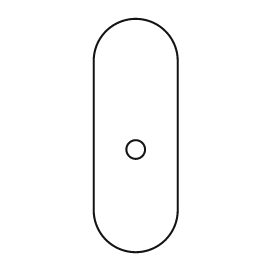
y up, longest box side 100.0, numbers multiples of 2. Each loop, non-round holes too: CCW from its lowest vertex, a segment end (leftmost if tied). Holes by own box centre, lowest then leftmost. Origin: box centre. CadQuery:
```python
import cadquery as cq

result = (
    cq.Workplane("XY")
    .moveTo(-18.0, -32.0)
    .threePointArc((0.0, -50.0), (18.0, -32.0))
    .lineTo(18.0, 32.0)
    .threePointArc((0.0, 50.0), (-18.0, 32.0))
    .close()
    .moveTo(0.0, -6.0)
    .circle(4.0)
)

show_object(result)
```